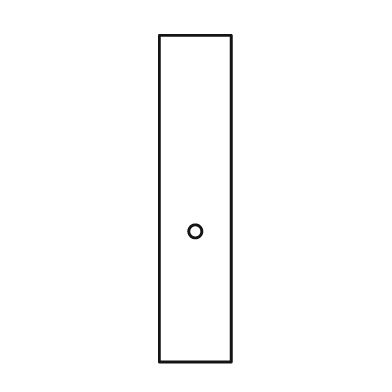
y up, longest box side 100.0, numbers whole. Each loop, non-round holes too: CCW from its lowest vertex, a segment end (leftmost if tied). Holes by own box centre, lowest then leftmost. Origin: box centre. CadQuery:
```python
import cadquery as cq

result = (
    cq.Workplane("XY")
    .moveTo(-11.0, -50.0)
    .lineTo(11.0, -50.0)
    .lineTo(11.0, 50.0)
    .lineTo(-11.0, 50.0)
    .close()
    .moveTo(0.0, -10.0)
    .circle(2.0)
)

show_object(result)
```